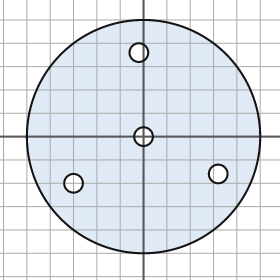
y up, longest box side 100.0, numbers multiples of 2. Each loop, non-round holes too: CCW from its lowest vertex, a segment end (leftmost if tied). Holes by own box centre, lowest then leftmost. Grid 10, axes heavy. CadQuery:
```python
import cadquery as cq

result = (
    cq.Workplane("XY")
    .moveTo(0.0, 0.0)
    .circle(50.0)
    .moveTo(-30.0, -20.0)
    .circle(4.0)
    .moveTo(32.0, -16.0)
    .circle(4.0)
    .moveTo(0.0, 0.0)
    .circle(4.0)
    .moveTo(-2.0, 36.0)
    .circle(4.0)
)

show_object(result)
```